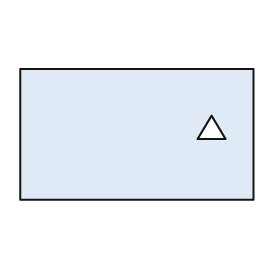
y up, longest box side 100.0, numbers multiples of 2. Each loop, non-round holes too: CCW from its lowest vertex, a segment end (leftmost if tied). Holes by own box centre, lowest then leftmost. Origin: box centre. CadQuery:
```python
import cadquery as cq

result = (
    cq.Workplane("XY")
    .moveTo(-50.0, -28.0)
    .lineTo(50.0, -28.0)
    .lineTo(50.0, 28.0)
    .lineTo(-50.0, 28.0)
    .close()
    .moveTo(26.0, -2.0)
    .lineTo(38.0, -2.0)
    .lineTo(32.0, 8.0)
    .close()
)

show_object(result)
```